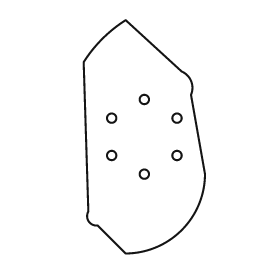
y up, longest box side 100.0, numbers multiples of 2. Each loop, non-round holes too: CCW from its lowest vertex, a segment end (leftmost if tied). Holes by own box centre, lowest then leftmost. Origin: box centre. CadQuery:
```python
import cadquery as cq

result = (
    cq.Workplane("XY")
    .moveTo(-8.0, -50.0)
    .threePointArc((16.0, -40.0), (26.0, -16.0))
    .lineTo(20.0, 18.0)
    .threePointArc((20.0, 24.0), (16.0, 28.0))
    .lineTo(-8.0, 50.0)
    .threePointArc((-18.0, 42.0), (-26.0, 32.0))
    .lineTo(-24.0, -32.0)
    .threePointArc((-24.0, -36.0), (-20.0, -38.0))
    .close()
    .moveTo(0.0, -16.0)
    .circle(2.0)
    .moveTo(-14.0, -8.0)
    .circle(2.0)
    .moveTo(14.0, -8.0)
    .circle(2.0)
    .moveTo(-14.0, 8.0)
    .circle(2.0)
    .moveTo(14.0, 8.0)
    .circle(2.0)
    .moveTo(0.0, 16.0)
    .circle(2.0)
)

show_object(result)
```